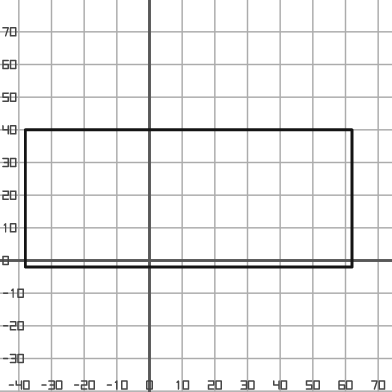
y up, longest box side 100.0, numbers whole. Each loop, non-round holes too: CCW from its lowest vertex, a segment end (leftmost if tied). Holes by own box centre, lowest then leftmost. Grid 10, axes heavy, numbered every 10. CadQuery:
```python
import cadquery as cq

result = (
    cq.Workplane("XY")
    .moveTo(-38.0, -2.0)
    .lineTo(62.0, -2.0)
    .lineTo(62.0, 40.0)
    .lineTo(-38.0, 40.0)
    .close()
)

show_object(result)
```